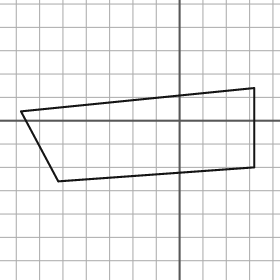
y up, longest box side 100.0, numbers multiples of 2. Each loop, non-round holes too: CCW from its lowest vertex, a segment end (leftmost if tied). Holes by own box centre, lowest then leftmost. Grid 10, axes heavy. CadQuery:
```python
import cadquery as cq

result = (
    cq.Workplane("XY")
    .moveTo(-52.0, -26.0)
    .lineTo(32.0, -20.0)
    .lineTo(32.0, 14.0)
    .lineTo(-68.0, 4.0)
    .close()
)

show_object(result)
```